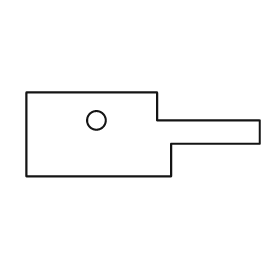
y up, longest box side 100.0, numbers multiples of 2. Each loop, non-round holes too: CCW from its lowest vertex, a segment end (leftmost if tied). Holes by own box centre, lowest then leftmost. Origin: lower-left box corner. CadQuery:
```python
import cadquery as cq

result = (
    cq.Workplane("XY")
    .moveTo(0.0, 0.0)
    .lineTo(62.0, 0.0)
    .lineTo(62.0, 14.0)
    .lineTo(100.0, 14.0)
    .lineTo(100.0, 24.0)
    .lineTo(56.0, 24.0)
    .lineTo(56.0, 36.0)
    .lineTo(0.0, 36.0)
    .close()
    .moveTo(30.0, 24.0)
    .circle(4.0)
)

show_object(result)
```